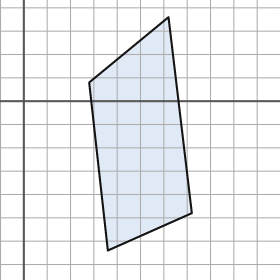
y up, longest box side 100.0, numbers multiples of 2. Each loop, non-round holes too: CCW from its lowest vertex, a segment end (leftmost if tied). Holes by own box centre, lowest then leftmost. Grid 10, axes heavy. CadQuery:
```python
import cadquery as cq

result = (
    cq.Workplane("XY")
    .moveTo(36.0, -64.0)
    .lineTo(72.0, -48.0)
    .lineTo(62.0, 36.0)
    .lineTo(28.0, 8.0)
    .close()
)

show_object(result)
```